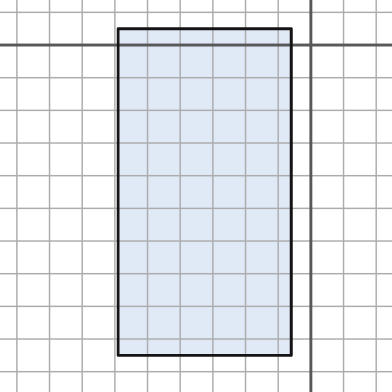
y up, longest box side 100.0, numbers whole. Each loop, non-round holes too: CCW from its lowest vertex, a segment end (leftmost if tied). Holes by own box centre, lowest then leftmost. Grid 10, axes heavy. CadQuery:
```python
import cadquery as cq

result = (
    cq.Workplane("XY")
    .moveTo(-59.0, -95.0)
    .lineTo(-6.0, -95.0)
    .lineTo(-6.0, 5.0)
    .lineTo(-59.0, 5.0)
    .close()
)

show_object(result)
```